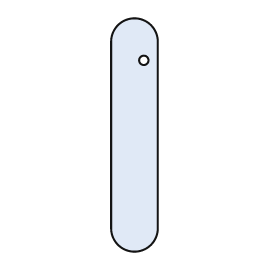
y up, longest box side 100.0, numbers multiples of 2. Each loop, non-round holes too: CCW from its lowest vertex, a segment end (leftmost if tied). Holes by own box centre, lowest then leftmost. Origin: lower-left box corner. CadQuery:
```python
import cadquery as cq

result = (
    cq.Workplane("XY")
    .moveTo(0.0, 10.0)
    .threePointArc((10.0, 0.0), (20.0, 10.0))
    .lineTo(20.0, 90.0)
    .threePointArc((10.0, 100.0), (0.0, 90.0))
    .close()
    .moveTo(14.0, 82.0)
    .circle(2.0)
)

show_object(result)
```